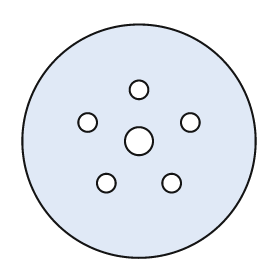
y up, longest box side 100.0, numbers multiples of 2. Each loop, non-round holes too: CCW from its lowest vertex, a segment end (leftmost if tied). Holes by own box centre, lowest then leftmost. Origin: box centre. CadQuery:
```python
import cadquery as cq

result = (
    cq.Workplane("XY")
    .moveTo(0.0, 0.0)
    .circle(50.0)
    .moveTo(-14.0, -18.0)
    .circle(4.0)
    .moveTo(14.0, -18.0)
    .circle(4.0)
    .moveTo(0.0, 0.0)
    .circle(6.0)
    .moveTo(-22.0, 8.0)
    .circle(4.0)
    .moveTo(22.0, 8.0)
    .circle(4.0)
    .moveTo(0.0, 22.0)
    .circle(4.0)
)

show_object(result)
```